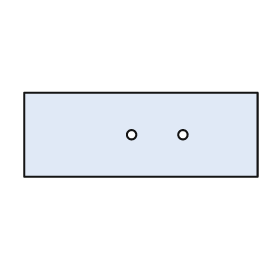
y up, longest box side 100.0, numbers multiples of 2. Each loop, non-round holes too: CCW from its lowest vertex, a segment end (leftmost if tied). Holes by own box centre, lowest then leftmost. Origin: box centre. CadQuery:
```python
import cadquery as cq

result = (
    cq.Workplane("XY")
    .moveTo(-50.0, -18.0)
    .lineTo(50.0, -18.0)
    .lineTo(50.0, 18.0)
    .lineTo(-50.0, 18.0)
    .close()
    .moveTo(-4.0, 0.0)
    .circle(2.0)
    .moveTo(18.0, 0.0)
    .circle(2.0)
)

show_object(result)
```